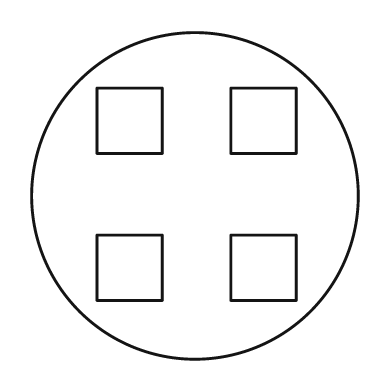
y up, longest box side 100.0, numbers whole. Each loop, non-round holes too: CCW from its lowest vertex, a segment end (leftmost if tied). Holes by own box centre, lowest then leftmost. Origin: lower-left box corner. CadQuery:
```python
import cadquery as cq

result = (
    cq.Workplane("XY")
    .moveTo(50.0, 50.0)
    .circle(50.0)
    .moveTo(20.0, 18.0)
    .lineTo(40.0, 18.0)
    .lineTo(40.0, 38.0)
    .lineTo(20.0, 38.0)
    .close()
    .moveTo(61.0, 18.0)
    .lineTo(81.0, 18.0)
    .lineTo(81.0, 38.0)
    .lineTo(61.0, 38.0)
    .close()
    .moveTo(20.0, 63.0)
    .lineTo(40.0, 63.0)
    .lineTo(40.0, 83.0)
    .lineTo(20.0, 83.0)
    .close()
    .moveTo(61.0, 63.0)
    .lineTo(81.0, 63.0)
    .lineTo(81.0, 83.0)
    .lineTo(61.0, 83.0)
    .close()
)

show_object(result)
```